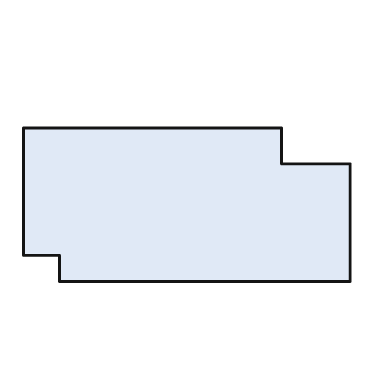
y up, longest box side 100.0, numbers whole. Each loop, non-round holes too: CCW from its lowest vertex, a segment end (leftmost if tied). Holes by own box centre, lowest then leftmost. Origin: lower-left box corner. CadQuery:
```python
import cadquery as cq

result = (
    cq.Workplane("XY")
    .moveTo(11.0, 0.0)
    .lineTo(100.0, 0.0)
    .lineTo(100.0, 36.0)
    .lineTo(79.0, 36.0)
    .lineTo(79.0, 47.0)
    .lineTo(0.0, 47.0)
    .lineTo(0.0, 8.0)
    .lineTo(11.0, 8.0)
    .close()
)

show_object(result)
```